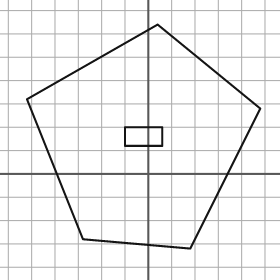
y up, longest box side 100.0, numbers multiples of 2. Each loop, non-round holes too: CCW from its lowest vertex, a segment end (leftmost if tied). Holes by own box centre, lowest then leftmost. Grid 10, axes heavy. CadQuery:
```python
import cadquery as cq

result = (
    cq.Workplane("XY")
    .moveTo(18.0, -32.0)
    .lineTo(48.0, 28.0)
    .lineTo(4.0, 64.0)
    .lineTo(-52.0, 32.0)
    .lineTo(-28.0, -28.0)
    .close()
    .moveTo(-10.0, 12.0)
    .lineTo(6.0, 12.0)
    .lineTo(6.0, 20.0)
    .lineTo(-10.0, 20.0)
    .close()
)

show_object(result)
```